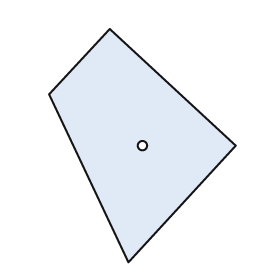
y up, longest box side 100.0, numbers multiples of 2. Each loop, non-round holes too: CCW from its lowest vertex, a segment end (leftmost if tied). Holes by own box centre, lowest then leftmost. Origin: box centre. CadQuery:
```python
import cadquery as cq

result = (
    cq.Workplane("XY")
    .moveTo(-6.0, -50.0)
    .lineTo(40.0, 0.0)
    .lineTo(-14.0, 50.0)
    .lineTo(-40.0, 22.0)
    .close()
    .moveTo(0.0, 0.0)
    .circle(2.0)
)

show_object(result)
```